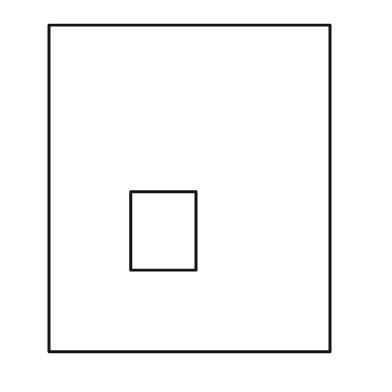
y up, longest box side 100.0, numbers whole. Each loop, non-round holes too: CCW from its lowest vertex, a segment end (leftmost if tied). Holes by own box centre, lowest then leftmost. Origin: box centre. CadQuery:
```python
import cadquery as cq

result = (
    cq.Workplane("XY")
    .moveTo(-43.0, -50.0)
    .lineTo(43.0, -50.0)
    .lineTo(43.0, 50.0)
    .lineTo(-43.0, 50.0)
    .close()
    .moveTo(-18.0, -25.0)
    .lineTo(2.0, -25.0)
    .lineTo(2.0, -1.0)
    .lineTo(-18.0, -1.0)
    .close()
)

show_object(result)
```